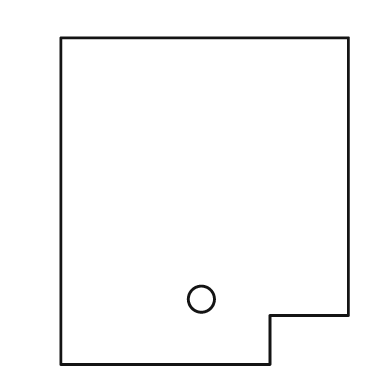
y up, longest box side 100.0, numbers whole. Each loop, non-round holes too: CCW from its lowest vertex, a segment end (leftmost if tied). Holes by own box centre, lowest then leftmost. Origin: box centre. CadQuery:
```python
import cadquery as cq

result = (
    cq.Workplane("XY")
    .moveTo(-44.0, -50.0)
    .lineTo(20.0, -50.0)
    .lineTo(20.0, -35.0)
    .lineTo(44.0, -35.0)
    .lineTo(44.0, 50.0)
    .lineTo(-44.0, 50.0)
    .close()
    .moveTo(-1.0, -30.0)
    .circle(4.0)
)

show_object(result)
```